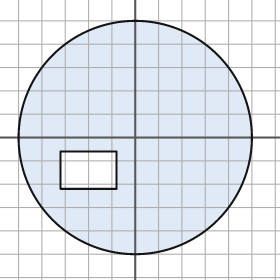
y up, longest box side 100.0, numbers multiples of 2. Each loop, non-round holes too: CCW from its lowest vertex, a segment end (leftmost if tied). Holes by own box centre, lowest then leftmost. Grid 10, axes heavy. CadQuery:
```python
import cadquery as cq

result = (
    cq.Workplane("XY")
    .moveTo(0.0, 0.0)
    .circle(50.0)
    .moveTo(-32.0, -22.0)
    .lineTo(-8.0, -22.0)
    .lineTo(-8.0, -6.0)
    .lineTo(-32.0, -6.0)
    .close()
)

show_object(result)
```